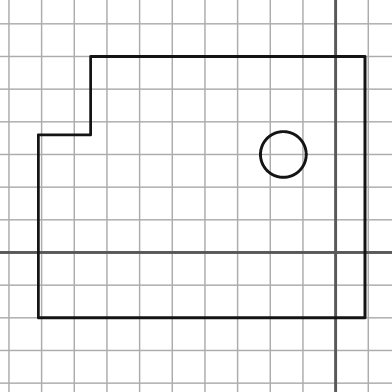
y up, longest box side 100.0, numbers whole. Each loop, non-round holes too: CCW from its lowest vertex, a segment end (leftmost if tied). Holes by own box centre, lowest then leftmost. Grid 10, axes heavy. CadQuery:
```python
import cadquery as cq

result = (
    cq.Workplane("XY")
    .moveTo(-91.0, -20.0)
    .lineTo(9.0, -20.0)
    .lineTo(9.0, 60.0)
    .lineTo(-75.0, 60.0)
    .lineTo(-75.0, 36.0)
    .lineTo(-91.0, 36.0)
    .close()
    .moveTo(-16.0, 30.0)
    .circle(7.0)
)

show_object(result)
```